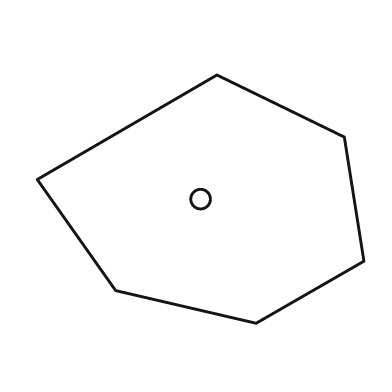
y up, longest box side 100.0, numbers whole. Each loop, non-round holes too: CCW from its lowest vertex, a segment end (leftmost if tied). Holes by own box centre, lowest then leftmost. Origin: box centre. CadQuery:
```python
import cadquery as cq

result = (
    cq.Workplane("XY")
    .moveTo(17.0, -38.0)
    .lineTo(50.0, -19.0)
    .lineTo(44.0, 19.0)
    .lineTo(5.0, 38.0)
    .lineTo(-50.0, 6.0)
    .lineTo(-26.0, -28.0)
    .close()
    .moveTo(0.0, 0.0)
    .circle(3.0)
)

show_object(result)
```